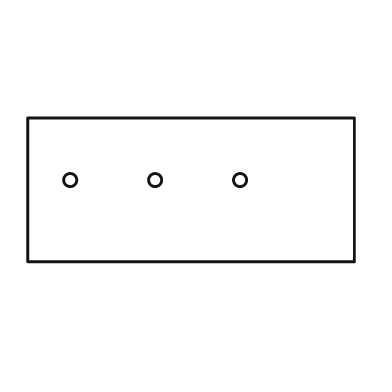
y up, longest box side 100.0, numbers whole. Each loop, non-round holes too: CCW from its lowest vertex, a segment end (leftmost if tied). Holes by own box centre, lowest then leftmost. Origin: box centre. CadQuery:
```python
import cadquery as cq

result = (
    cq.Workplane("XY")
    .moveTo(-50.0, -22.0)
    .lineTo(50.0, -22.0)
    .lineTo(50.0, 22.0)
    .lineTo(-50.0, 22.0)
    .close()
    .moveTo(-37.0, 3.0)
    .circle(2.0)
    .moveTo(-11.0, 3.0)
    .circle(2.0)
    .moveTo(15.0, 3.0)
    .circle(2.0)
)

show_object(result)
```